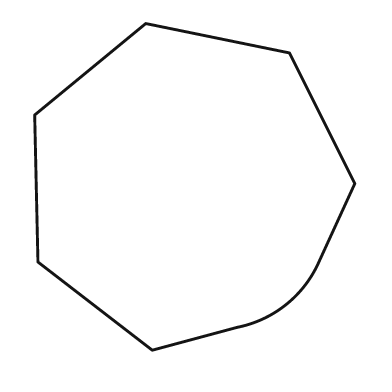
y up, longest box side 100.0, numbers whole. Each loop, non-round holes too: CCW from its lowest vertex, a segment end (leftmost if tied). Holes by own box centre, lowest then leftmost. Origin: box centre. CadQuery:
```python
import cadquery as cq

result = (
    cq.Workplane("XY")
    .moveTo(-13.0, -50.0)
    .lineTo(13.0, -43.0)
    .threePointArc((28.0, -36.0), (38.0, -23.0))
    .lineTo(49.0, 1.0)
    .lineTo(29.0, 41.0)
    .lineTo(-15.0, 50.0)
    .lineTo(-49.0, 22.0)
    .lineTo(-48.0, -23.0)
    .close()
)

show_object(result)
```